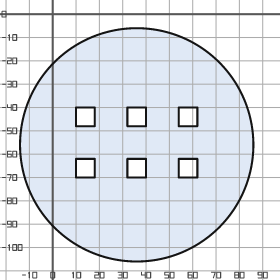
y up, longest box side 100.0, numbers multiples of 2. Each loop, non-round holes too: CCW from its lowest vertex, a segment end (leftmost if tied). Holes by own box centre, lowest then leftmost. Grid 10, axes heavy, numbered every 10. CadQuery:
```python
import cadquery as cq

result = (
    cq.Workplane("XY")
    .moveTo(36.0, -56.0)
    .circle(50.0)
    .moveTo(10.0, -70.0)
    .lineTo(18.0, -70.0)
    .lineTo(18.0, -62.0)
    .lineTo(10.0, -62.0)
    .close()
    .moveTo(32.0, -70.0)
    .lineTo(40.0, -70.0)
    .lineTo(40.0, -62.0)
    .lineTo(32.0, -62.0)
    .close()
    .moveTo(54.0, -70.0)
    .lineTo(62.0, -70.0)
    .lineTo(62.0, -62.0)
    .lineTo(54.0, -62.0)
    .close()
    .moveTo(10.0, -48.0)
    .lineTo(18.0, -48.0)
    .lineTo(18.0, -40.0)
    .lineTo(10.0, -40.0)
    .close()
    .moveTo(32.0, -48.0)
    .lineTo(40.0, -48.0)
    .lineTo(40.0, -40.0)
    .lineTo(32.0, -40.0)
    .close()
    .moveTo(54.0, -48.0)
    .lineTo(62.0, -48.0)
    .lineTo(62.0, -40.0)
    .lineTo(54.0, -40.0)
    .close()
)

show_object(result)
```